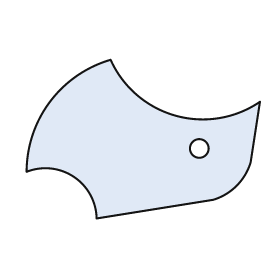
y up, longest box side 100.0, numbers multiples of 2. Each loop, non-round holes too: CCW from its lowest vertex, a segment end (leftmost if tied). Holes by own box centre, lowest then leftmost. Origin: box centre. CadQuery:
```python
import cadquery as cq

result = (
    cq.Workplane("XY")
    .moveTo(-20.0, -34.0)
    .lineTo(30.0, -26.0)
    .threePointArc((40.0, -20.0), (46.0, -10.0))
    .lineTo(50.0, 16.0)
    .threePointArc((14.0, 10.0), (-14.0, 34.0))
    .threePointArc((-40.0, 16.0), (-50.0, -14.0))
    .threePointArc((-30.0, -16.0), (-20.0, -34.0))
    .close()
    .moveTo(24.0, -4.0)
    .circle(4.0)
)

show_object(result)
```